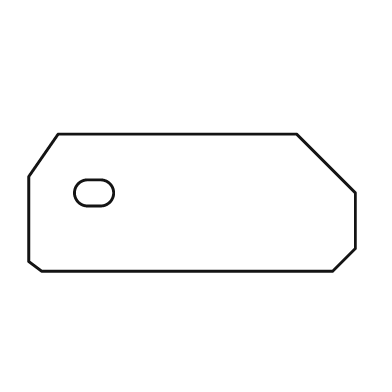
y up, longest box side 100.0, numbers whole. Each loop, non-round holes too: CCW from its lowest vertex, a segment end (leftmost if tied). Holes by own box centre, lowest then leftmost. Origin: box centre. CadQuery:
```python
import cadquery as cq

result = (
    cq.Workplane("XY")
    .moveTo(-46.0, -21.0)
    .lineTo(43.0, -21.0)
    .lineTo(50.0, -14.0)
    .lineTo(50.0, 3.0)
    .lineTo(32.0, 21.0)
    .lineTo(-41.0, 21.0)
    .lineTo(-50.0, 8.0)
    .lineTo(-50.0, -18.0)
    .close()
    .moveTo(-32.0, -1.0)
    .lineTo(-28.0, -1.0)
    .threePointArc((-24.0, 3.0), (-28.0, 7.0))
    .lineTo(-32.0, 7.0)
    .threePointArc((-36.0, 3.0), (-32.0, -1.0))
    .close()
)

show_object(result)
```